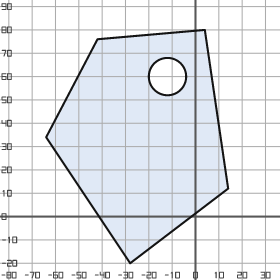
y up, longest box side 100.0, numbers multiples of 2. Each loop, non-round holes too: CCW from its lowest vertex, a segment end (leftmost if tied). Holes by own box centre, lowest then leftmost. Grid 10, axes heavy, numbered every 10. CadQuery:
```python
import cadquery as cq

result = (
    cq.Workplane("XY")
    .moveTo(-28.0, -20.0)
    .lineTo(14.0, 12.0)
    .lineTo(4.0, 80.0)
    .lineTo(-42.0, 76.0)
    .lineTo(-64.0, 34.0)
    .close()
    .moveTo(-12.0, 60.0)
    .circle(8.0)
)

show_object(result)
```